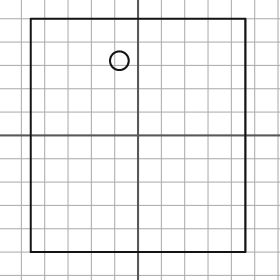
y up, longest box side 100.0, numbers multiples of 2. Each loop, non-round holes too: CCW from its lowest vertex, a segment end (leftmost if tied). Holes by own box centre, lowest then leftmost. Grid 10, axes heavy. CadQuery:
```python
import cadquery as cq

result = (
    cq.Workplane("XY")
    .moveTo(-46.0, -50.0)
    .lineTo(46.0, -50.0)
    .lineTo(46.0, 50.0)
    .lineTo(-46.0, 50.0)
    .close()
    .moveTo(-8.0, 32.0)
    .circle(4.0)
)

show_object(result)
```